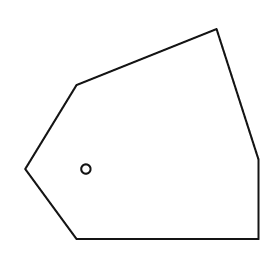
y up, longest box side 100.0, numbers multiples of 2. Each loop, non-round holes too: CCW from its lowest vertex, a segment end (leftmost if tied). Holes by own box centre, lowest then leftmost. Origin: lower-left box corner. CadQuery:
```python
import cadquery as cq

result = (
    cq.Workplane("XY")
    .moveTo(22.0, 0.0)
    .lineTo(100.0, 0.0)
    .lineTo(100.0, 34.0)
    .lineTo(82.0, 90.0)
    .lineTo(22.0, 66.0)
    .lineTo(0.0, 30.0)
    .close()
    .moveTo(26.0, 30.0)
    .circle(2.0)
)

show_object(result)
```